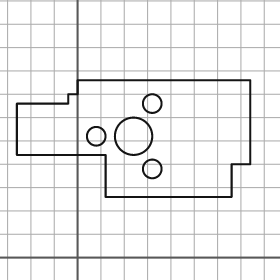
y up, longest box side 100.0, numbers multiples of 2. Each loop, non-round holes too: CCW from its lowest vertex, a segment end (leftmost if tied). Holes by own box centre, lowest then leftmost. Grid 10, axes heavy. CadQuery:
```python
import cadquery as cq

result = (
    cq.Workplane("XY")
    .moveTo(12.0, 26.0)
    .lineTo(66.0, 26.0)
    .lineTo(66.0, 40.0)
    .lineTo(74.0, 40.0)
    .lineTo(74.0, 76.0)
    .lineTo(0.0, 76.0)
    .lineTo(0.0, 70.0)
    .lineTo(-4.0, 70.0)
    .lineTo(-4.0, 66.0)
    .lineTo(-26.0, 66.0)
    .lineTo(-26.0, 44.0)
    .lineTo(12.0, 44.0)
    .close()
    .moveTo(32.0, 38.0)
    .circle(4.0)
    .moveTo(8.0, 52.0)
    .circle(4.0)
    .moveTo(24.0, 52.0)
    .circle(8.0)
    .moveTo(32.0, 66.0)
    .circle(4.0)
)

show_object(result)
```